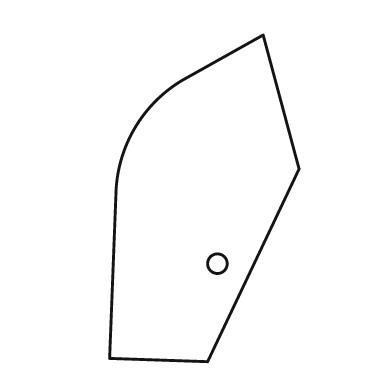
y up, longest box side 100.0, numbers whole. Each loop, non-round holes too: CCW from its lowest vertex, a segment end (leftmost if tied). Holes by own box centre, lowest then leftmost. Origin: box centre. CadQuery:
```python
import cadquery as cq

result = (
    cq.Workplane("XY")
    .moveTo(1.0, -50.0)
    .lineTo(29.0, 9.0)
    .lineTo(18.0, 50.0)
    .lineTo(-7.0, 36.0)
    .threePointArc((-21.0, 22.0), (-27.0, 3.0))
    .lineTo(-29.0, -49.0)
    .close()
    .moveTo(4.0, -20.0)
    .circle(3.0)
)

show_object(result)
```